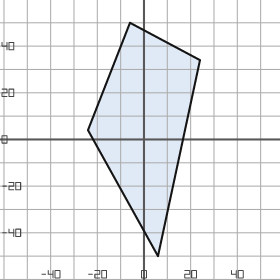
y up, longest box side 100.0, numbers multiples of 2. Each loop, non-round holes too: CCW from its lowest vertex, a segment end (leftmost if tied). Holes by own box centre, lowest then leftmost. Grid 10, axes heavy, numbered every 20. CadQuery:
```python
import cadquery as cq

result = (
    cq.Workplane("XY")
    .moveTo(6.0, -50.0)
    .lineTo(24.0, 34.0)
    .lineTo(-6.0, 50.0)
    .lineTo(-24.0, 4.0)
    .close()
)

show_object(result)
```